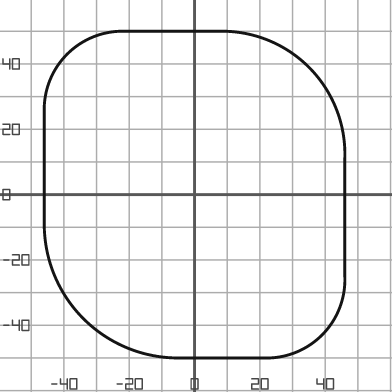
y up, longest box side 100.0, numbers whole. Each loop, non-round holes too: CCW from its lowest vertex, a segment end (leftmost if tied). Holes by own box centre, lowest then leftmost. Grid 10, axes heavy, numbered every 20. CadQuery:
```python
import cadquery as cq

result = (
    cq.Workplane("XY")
    .moveTo(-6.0, -50.0)
    .lineTo(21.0, -50.0)
    .threePointArc((39.0, -43.0), (46.0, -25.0))
    .lineTo(46.0, 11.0)
    .threePointArc((35.0, 39.0), (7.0, 50.0))
    .lineTo(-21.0, 50.0)
    .threePointArc((-39.0, 43.0), (-46.0, 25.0))
    .lineTo(-46.0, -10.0)
    .threePointArc((-34.0, -38.0), (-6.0, -50.0))
    .close()
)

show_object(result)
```